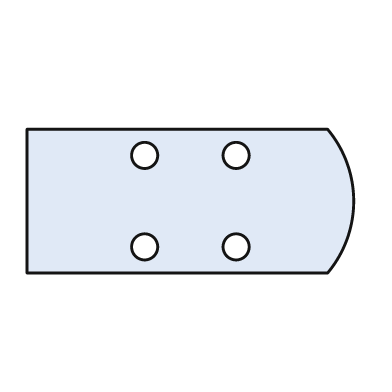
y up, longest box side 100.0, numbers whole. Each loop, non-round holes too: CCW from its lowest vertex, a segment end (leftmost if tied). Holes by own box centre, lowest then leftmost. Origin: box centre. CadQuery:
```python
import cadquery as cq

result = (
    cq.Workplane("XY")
    .moveTo(-50.0, -22.0)
    .lineTo(42.0, -22.0)
    .threePointArc((50.0, 0.0), (42.0, 22.0))
    .lineTo(-50.0, 22.0)
    .close()
    .moveTo(-14.0, -14.0)
    .circle(4.0)
    .moveTo(14.0, -14.0)
    .circle(4.0)
    .moveTo(-14.0, 14.0)
    .circle(4.0)
    .moveTo(14.0, 14.0)
    .circle(4.0)
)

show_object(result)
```